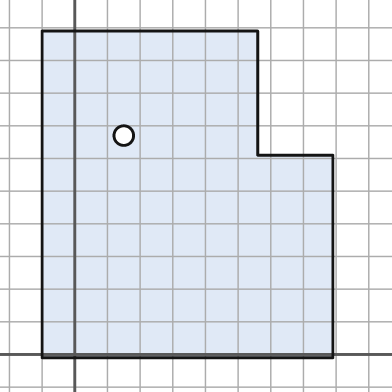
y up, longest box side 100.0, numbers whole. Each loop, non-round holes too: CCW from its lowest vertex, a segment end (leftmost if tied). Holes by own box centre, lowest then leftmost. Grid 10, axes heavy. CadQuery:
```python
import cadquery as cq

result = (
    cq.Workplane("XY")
    .moveTo(-10.0, -1.0)
    .lineTo(79.0, -1.0)
    .lineTo(79.0, 61.0)
    .lineTo(56.0, 61.0)
    .lineTo(56.0, 99.0)
    .lineTo(-10.0, 99.0)
    .close()
    .moveTo(15.0, 67.0)
    .circle(3.0)
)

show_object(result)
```